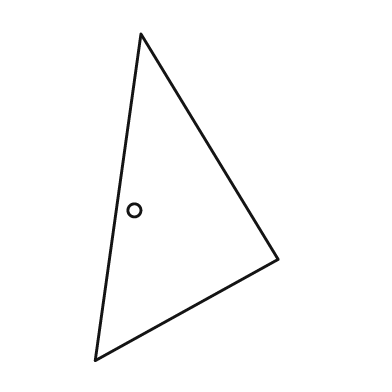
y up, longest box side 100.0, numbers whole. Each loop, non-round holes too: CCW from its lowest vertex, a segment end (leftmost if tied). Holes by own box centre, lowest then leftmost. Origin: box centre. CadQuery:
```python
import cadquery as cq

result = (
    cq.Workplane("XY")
    .moveTo(-28.0, -50.0)
    .lineTo(28.0, -19.0)
    .lineTo(-14.0, 50.0)
    .close()
    .moveTo(-16.0, -4.0)
    .circle(2.0)
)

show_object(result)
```